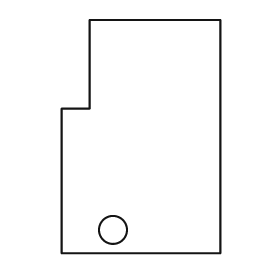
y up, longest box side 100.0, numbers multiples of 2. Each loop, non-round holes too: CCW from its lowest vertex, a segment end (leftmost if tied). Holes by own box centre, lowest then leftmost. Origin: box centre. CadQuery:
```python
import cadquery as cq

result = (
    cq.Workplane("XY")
    .moveTo(-34.0, -50.0)
    .lineTo(34.0, -50.0)
    .lineTo(34.0, 50.0)
    .lineTo(-22.0, 50.0)
    .lineTo(-22.0, 12.0)
    .lineTo(-34.0, 12.0)
    .close()
    .moveTo(-12.0, -40.0)
    .circle(6.0)
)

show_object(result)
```